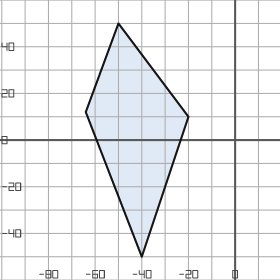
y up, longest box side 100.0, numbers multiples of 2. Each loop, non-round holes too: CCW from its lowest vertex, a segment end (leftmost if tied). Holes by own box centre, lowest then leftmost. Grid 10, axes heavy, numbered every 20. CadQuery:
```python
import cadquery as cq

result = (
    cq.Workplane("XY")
    .moveTo(-40.0, -50.0)
    .lineTo(-20.0, 10.0)
    .lineTo(-50.0, 50.0)
    .lineTo(-64.0, 12.0)
    .close()
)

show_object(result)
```